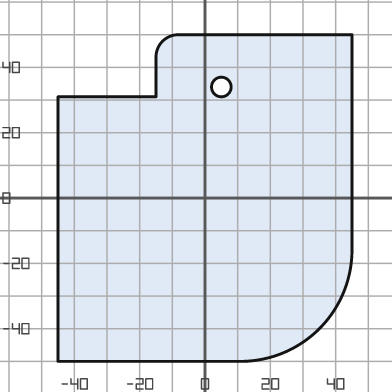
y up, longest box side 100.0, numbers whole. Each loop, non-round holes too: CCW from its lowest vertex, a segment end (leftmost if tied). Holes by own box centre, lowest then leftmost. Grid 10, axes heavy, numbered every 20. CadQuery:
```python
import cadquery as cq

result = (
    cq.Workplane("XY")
    .moveTo(-45.0, -50.0)
    .lineTo(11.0, -50.0)
    .threePointArc((35.0, -40.0), (45.0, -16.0))
    .lineTo(45.0, 50.0)
    .lineTo(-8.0, 50.0)
    .threePointArc((-13.0, 48.0), (-15.0, 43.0))
    .lineTo(-15.0, 31.0)
    .lineTo(-45.0, 31.0)
    .close()
    .moveTo(5.0, 34.0)
    .circle(3.0)
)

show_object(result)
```